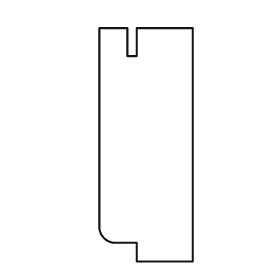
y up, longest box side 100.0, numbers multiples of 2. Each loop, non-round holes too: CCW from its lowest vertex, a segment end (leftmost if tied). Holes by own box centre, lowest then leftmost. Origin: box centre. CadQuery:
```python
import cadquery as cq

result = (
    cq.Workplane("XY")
    .moveTo(-4.0, -50.0)
    .lineTo(20.0, -50.0)
    .lineTo(20.0, 50.0)
    .lineTo(-4.0, 50.0)
    .lineTo(-4.0, 38.0)
    .lineTo(-8.0, 38.0)
    .lineTo(-8.0, 50.0)
    .lineTo(-20.0, 50.0)
    .lineTo(-20.0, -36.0)
    .threePointArc((-18.0, -40.0), (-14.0, -42.0))
    .lineTo(-4.0, -42.0)
    .close()
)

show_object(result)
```